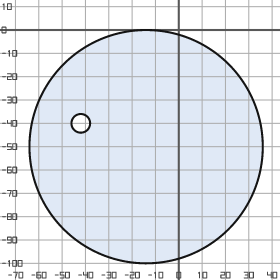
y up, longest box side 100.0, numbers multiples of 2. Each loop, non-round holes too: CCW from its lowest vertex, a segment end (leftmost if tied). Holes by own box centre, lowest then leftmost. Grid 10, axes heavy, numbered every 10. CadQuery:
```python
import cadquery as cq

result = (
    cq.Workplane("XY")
    .moveTo(-14.0, -50.0)
    .circle(50.0)
    .moveTo(-42.0, -40.0)
    .circle(4.0)
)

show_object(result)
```